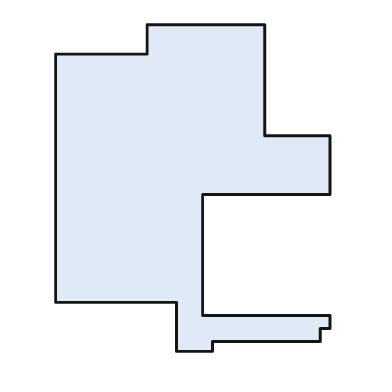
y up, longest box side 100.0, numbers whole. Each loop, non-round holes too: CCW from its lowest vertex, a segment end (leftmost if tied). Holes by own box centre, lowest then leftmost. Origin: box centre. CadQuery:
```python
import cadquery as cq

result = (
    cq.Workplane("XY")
    .moveTo(-5.0, -50.0)
    .lineTo(6.0, -50.0)
    .lineTo(6.0, -47.0)
    .lineTo(39.0, -47.0)
    .lineTo(39.0, -43.0)
    .lineTo(42.0, -43.0)
    .lineTo(42.0, -39.0)
    .lineTo(3.0, -39.0)
    .lineTo(3.0, -2.0)
    .lineTo(42.0, -2.0)
    .lineTo(42.0, 16.0)
    .lineTo(22.0, 16.0)
    .lineTo(22.0, 50.0)
    .lineTo(-14.0, 50.0)
    .lineTo(-14.0, 41.0)
    .lineTo(-42.0, 41.0)
    .lineTo(-42.0, -35.0)
    .lineTo(-5.0, -35.0)
    .close()
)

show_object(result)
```